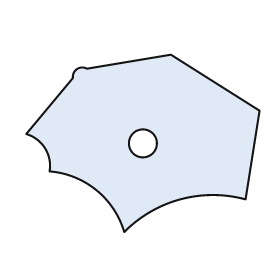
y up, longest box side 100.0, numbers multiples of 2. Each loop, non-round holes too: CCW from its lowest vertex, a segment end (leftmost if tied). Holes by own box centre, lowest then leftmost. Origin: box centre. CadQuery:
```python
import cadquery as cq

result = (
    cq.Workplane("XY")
    .moveTo(-8.0, -38.0)
    .threePointArc((16.0, -24.0), (44.0, -24.0))
    .lineTo(50.0, 14.0)
    .lineTo(12.0, 38.0)
    .lineTo(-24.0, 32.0)
    .threePointArc((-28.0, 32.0), (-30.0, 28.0))
    .lineTo(-50.0, 4.0)
    .threePointArc((-42.0, -2.0), (-40.0, -12.0))
    .threePointArc((-20.0, -20.0), (-8.0, -38.0))
    .close()
    .moveTo(0.0, 0.0)
    .circle(6.0)
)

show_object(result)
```